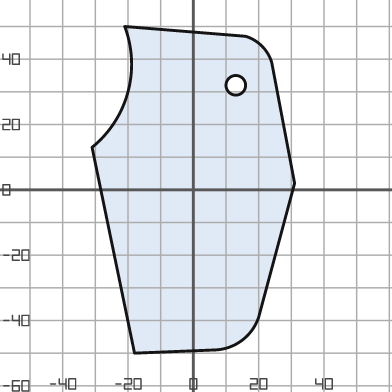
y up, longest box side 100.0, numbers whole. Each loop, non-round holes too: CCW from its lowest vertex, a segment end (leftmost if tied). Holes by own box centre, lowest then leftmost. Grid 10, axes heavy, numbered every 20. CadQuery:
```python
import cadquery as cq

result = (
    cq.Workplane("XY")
    .moveTo(-18.0, -50.0)
    .lineTo(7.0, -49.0)
    .threePointArc((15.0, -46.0), (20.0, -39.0))
    .lineTo(31.0, 2.0)
    .lineTo(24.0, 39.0)
    .threePointArc((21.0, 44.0), (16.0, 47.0))
    .lineTo(-21.0, 50.0)
    .threePointArc((-20.0, 30.0), (-31.0, 13.0))
    .close()
    .moveTo(13.0, 32.0)
    .circle(3.0)
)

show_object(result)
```